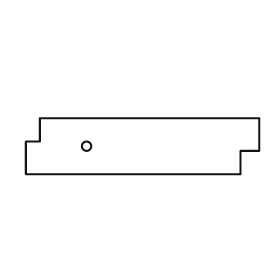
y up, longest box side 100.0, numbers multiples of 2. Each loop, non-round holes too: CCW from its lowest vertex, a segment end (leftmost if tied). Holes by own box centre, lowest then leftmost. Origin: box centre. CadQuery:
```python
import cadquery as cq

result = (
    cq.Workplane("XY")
    .moveTo(-50.0, -12.0)
    .lineTo(42.0, -12.0)
    .lineTo(42.0, -2.0)
    .lineTo(50.0, -2.0)
    .lineTo(50.0, 12.0)
    .lineTo(-44.0, 12.0)
    .lineTo(-44.0, 2.0)
    .lineTo(-50.0, 2.0)
    .close()
    .moveTo(-24.0, 0.0)
    .circle(2.0)
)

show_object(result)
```